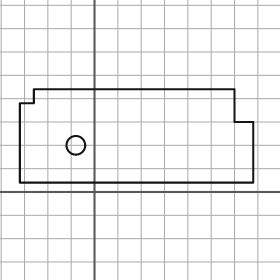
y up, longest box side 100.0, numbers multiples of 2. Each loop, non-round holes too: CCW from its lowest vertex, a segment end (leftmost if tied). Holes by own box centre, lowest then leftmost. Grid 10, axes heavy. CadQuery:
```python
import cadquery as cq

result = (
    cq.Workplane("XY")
    .moveTo(-32.0, 4.0)
    .lineTo(68.0, 4.0)
    .lineTo(68.0, 30.0)
    .lineTo(60.0, 30.0)
    .lineTo(60.0, 44.0)
    .lineTo(-26.0, 44.0)
    .lineTo(-26.0, 38.0)
    .lineTo(-32.0, 38.0)
    .close()
    .moveTo(-8.0, 20.0)
    .circle(4.0)
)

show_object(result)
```